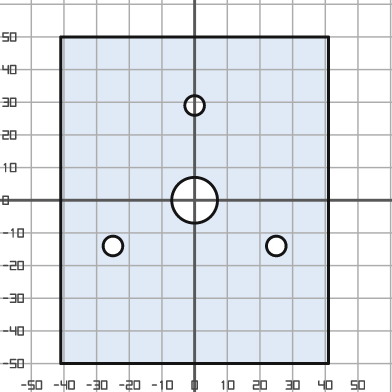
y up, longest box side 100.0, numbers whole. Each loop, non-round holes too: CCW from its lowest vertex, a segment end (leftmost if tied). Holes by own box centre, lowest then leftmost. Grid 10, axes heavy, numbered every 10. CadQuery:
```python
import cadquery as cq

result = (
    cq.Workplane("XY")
    .moveTo(-41.0, -50.0)
    .lineTo(41.0, -50.0)
    .lineTo(41.0, 50.0)
    .lineTo(-41.0, 50.0)
    .close()
    .moveTo(-25.0, -14.0)
    .circle(3.0)
    .moveTo(25.0, -14.0)
    .circle(3.0)
    .moveTo(0.0, 0.0)
    .circle(7.0)
    .moveTo(0.0, 29.0)
    .circle(3.0)
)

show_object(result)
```